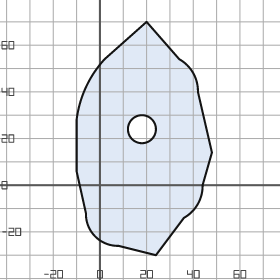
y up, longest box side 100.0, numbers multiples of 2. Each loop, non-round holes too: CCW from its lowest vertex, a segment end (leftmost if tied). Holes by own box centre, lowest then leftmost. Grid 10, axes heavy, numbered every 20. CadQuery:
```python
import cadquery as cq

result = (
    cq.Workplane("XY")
    .moveTo(24.0, -30.0)
    .lineTo(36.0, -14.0)
    .threePointArc((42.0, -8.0), (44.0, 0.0))
    .lineTo(48.0, 14.0)
    .lineTo(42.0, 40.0)
    .threePointArc((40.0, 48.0), (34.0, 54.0))
    .lineTo(20.0, 70.0)
    .lineTo(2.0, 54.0)
    .threePointArc((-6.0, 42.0), (-10.0, 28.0))
    .lineTo(-10.0, 6.0)
    .lineTo(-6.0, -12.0)
    .threePointArc((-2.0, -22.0), (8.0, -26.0))
    .close()
    .moveTo(18.0, 24.0)
    .circle(6.0)
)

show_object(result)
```